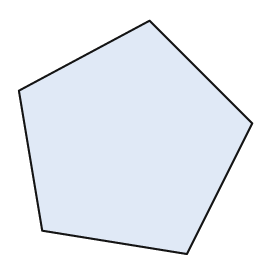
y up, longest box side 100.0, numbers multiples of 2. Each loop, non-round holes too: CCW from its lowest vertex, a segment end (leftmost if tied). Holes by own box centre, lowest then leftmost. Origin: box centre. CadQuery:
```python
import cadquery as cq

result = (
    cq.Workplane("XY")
    .moveTo(22.0, -50.0)
    .lineTo(50.0, 6.0)
    .lineTo(6.0, 50.0)
    .lineTo(-50.0, 20.0)
    .lineTo(-40.0, -40.0)
    .close()
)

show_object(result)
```